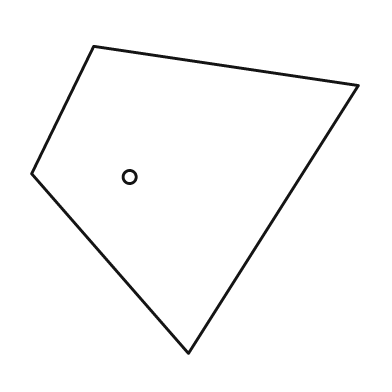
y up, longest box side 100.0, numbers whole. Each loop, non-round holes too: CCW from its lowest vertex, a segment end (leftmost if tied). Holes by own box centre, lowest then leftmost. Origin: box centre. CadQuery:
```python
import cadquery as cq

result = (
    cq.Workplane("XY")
    .moveTo(-2.0, -47.0)
    .lineTo(50.0, 35.0)
    .lineTo(-31.0, 47.0)
    .lineTo(-50.0, 8.0)
    .close()
    .moveTo(-20.0, 7.0)
    .circle(2.0)
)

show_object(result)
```